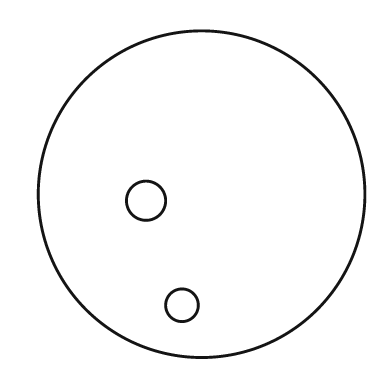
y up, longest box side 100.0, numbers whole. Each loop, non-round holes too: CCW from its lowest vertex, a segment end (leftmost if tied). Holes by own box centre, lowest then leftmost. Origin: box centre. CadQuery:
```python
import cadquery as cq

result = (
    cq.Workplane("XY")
    .moveTo(0.0, 0.0)
    .circle(50.0)
    .moveTo(-6.0, -34.0)
    .circle(5.0)
    .moveTo(-17.0, -2.0)
    .circle(6.0)
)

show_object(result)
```